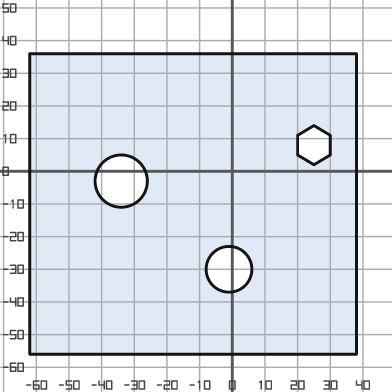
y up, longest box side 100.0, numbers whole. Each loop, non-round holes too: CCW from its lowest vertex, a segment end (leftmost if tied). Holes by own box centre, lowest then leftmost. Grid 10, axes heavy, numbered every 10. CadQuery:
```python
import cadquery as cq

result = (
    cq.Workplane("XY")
    .moveTo(-62.0, -56.0)
    .lineTo(38.0, -56.0)
    .lineTo(38.0, 36.0)
    .lineTo(-62.0, 36.0)
    .close()
    .moveTo(-1.0, -30.0)
    .circle(7.0)
    .moveTo(-34.0, -3.0)
    .circle(8.0)
    .moveTo(25.0, 2.0)
    .lineTo(30.0, 5.0)
    .lineTo(30.0, 11.0)
    .lineTo(25.0, 14.0)
    .lineTo(20.0, 11.0)
    .lineTo(20.0, 5.0)
    .close()
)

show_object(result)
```